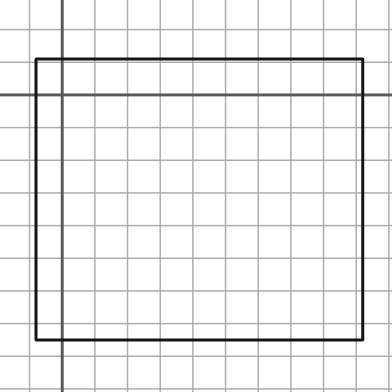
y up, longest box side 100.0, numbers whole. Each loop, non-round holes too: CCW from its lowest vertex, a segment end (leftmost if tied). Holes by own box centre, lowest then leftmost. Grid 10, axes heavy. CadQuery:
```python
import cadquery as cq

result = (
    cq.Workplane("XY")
    .moveTo(-8.0, -75.0)
    .lineTo(92.0, -75.0)
    .lineTo(92.0, 11.0)
    .lineTo(-8.0, 11.0)
    .close()
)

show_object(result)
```